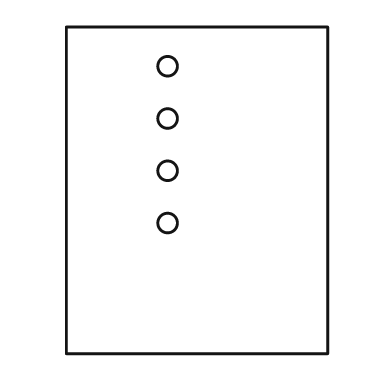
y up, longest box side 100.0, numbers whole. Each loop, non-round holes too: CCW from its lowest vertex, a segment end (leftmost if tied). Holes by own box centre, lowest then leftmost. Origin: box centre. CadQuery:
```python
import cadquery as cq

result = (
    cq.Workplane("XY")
    .moveTo(-40.0, -50.0)
    .lineTo(40.0, -50.0)
    .lineTo(40.0, 50.0)
    .lineTo(-40.0, 50.0)
    .close()
    .moveTo(-9.0, -10.0)
    .circle(3.0)
    .moveTo(-9.0, 6.0)
    .circle(3.0)
    .moveTo(-9.0, 22.0)
    .circle(3.0)
    .moveTo(-9.0, 38.0)
    .circle(3.0)
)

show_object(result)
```